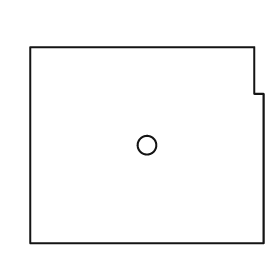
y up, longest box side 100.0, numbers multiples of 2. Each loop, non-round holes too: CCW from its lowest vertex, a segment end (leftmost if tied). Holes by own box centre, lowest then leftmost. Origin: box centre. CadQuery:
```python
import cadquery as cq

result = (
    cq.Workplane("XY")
    .moveTo(-50.0, -42.0)
    .lineTo(50.0, -42.0)
    .lineTo(50.0, 22.0)
    .lineTo(46.0, 22.0)
    .lineTo(46.0, 42.0)
    .lineTo(-50.0, 42.0)
    .close()
    .moveTo(0.0, 0.0)
    .circle(4.0)
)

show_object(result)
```